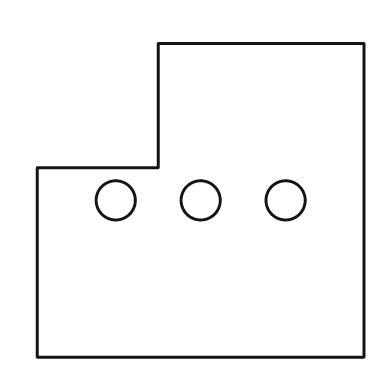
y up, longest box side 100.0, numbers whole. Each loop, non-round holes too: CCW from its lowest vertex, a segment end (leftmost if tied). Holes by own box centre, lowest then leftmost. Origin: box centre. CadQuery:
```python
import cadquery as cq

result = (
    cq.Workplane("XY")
    .moveTo(-50.0, -48.0)
    .lineTo(50.0, -48.0)
    .lineTo(50.0, 48.0)
    .lineTo(-13.0, 48.0)
    .lineTo(-13.0, 10.0)
    .lineTo(-50.0, 10.0)
    .close()
    .moveTo(-26.0, 0.0)
    .circle(6.0)
    .moveTo(0.0, 0.0)
    .circle(6.0)
    .moveTo(26.0, 0.0)
    .circle(6.0)
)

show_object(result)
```